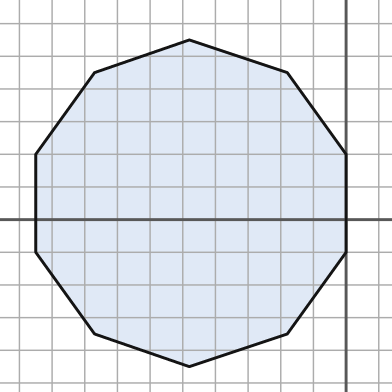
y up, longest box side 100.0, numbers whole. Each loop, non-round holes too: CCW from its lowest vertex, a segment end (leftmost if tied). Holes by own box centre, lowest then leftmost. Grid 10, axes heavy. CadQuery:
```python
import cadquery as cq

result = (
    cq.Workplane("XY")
    .moveTo(-48.0, -45.0)
    .lineTo(-18.0, -35.0)
    .lineTo(0.0, -10.0)
    .lineTo(0.0, 20.0)
    .lineTo(-18.0, 45.0)
    .lineTo(-48.0, 55.0)
    .lineTo(-77.0, 45.0)
    .lineTo(-95.0, 20.0)
    .lineTo(-95.0, -10.0)
    .lineTo(-77.0, -35.0)
    .close()
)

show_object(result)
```